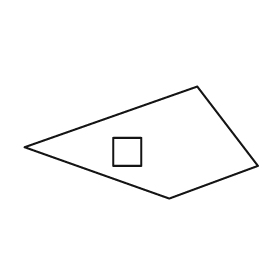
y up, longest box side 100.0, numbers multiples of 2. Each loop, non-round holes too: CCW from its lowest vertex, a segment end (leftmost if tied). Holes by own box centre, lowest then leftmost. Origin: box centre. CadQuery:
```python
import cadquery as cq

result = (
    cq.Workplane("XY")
    .moveTo(12.0, -24.0)
    .lineTo(50.0, -10.0)
    .lineTo(24.0, 24.0)
    .lineTo(-50.0, -2.0)
    .close()
    .moveTo(-12.0, -10.0)
    .lineTo(0.0, -10.0)
    .lineTo(0.0, 2.0)
    .lineTo(-12.0, 2.0)
    .close()
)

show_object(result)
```